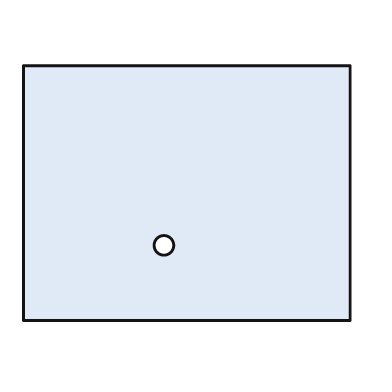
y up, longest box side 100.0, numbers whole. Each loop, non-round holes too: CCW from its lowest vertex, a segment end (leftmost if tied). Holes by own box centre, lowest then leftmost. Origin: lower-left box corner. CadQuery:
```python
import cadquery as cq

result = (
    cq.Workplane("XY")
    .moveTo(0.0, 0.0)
    .lineTo(100.0, 0.0)
    .lineTo(100.0, 78.0)
    .lineTo(0.0, 78.0)
    .close()
    .moveTo(43.0, 23.0)
    .circle(3.0)
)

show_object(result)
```